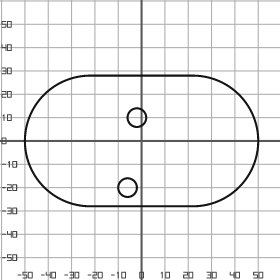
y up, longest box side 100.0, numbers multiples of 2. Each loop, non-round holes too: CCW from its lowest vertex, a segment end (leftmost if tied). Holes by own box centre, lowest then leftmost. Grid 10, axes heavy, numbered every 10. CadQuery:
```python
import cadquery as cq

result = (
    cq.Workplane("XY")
    .moveTo(-22.0, -28.0)
    .lineTo(22.0, -28.0)
    .threePointArc((50.0, 0.0), (22.0, 28.0))
    .lineTo(-22.0, 28.0)
    .threePointArc((-50.0, 0.0), (-22.0, -28.0))
    .close()
    .moveTo(-6.0, -20.0)
    .circle(4.0)
    .moveTo(-2.0, 10.0)
    .circle(4.0)
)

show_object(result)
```